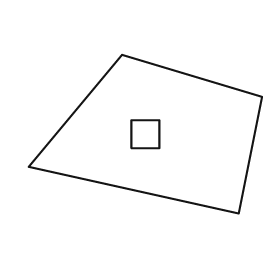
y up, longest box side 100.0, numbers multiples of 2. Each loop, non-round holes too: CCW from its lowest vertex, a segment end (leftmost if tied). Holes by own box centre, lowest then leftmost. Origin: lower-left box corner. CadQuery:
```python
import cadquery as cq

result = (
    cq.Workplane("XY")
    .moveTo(90.0, 0.0)
    .lineTo(100.0, 50.0)
    .lineTo(40.0, 68.0)
    .lineTo(0.0, 20.0)
    .close()
    .moveTo(44.0, 28.0)
    .lineTo(56.0, 28.0)
    .lineTo(56.0, 40.0)
    .lineTo(44.0, 40.0)
    .close()
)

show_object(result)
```